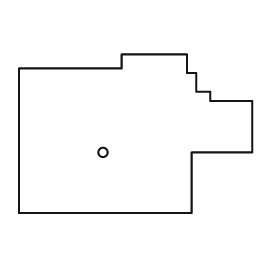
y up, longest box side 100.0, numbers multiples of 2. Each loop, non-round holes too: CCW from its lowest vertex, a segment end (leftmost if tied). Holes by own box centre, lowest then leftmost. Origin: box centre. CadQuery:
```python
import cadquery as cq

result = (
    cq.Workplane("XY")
    .moveTo(-50.0, -34.0)
    .lineTo(24.0, -34.0)
    .lineTo(24.0, -8.0)
    .lineTo(50.0, -8.0)
    .lineTo(50.0, 14.0)
    .lineTo(32.0, 14.0)
    .lineTo(32.0, 18.0)
    .lineTo(26.0, 18.0)
    .lineTo(26.0, 26.0)
    .lineTo(22.0, 26.0)
    .lineTo(22.0, 34.0)
    .lineTo(-6.0, 34.0)
    .lineTo(-6.0, 28.0)
    .lineTo(-50.0, 28.0)
    .close()
    .moveTo(-14.0, -8.0)
    .circle(2.0)
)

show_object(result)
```